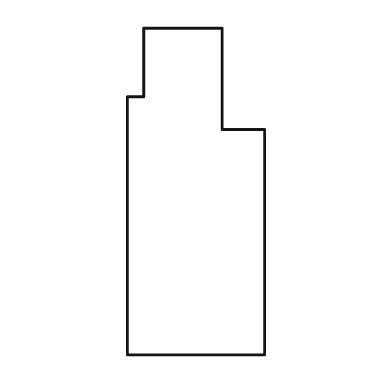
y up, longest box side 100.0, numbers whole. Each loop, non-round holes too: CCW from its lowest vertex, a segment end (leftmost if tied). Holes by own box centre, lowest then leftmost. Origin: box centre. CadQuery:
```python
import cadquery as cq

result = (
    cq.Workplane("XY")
    .moveTo(-21.0, -50.0)
    .lineTo(21.0, -50.0)
    .lineTo(21.0, 19.0)
    .lineTo(8.0, 19.0)
    .lineTo(8.0, 50.0)
    .lineTo(-16.0, 50.0)
    .lineTo(-16.0, 29.0)
    .lineTo(-21.0, 29.0)
    .close()
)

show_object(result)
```